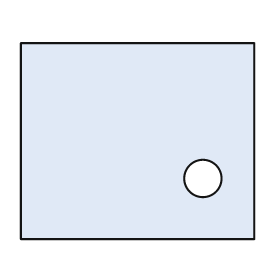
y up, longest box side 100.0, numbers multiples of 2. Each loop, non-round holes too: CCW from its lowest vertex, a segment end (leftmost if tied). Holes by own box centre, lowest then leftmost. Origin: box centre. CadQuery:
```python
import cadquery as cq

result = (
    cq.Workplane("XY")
    .moveTo(-50.0, -42.0)
    .lineTo(50.0, -42.0)
    .lineTo(50.0, 42.0)
    .lineTo(-50.0, 42.0)
    .close()
    .moveTo(28.0, -16.0)
    .circle(8.0)
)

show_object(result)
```